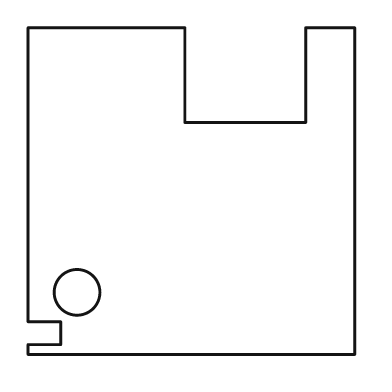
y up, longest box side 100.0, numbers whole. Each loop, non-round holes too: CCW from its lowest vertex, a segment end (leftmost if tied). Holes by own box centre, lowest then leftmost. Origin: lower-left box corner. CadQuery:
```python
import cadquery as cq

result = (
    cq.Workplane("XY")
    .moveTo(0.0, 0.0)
    .lineTo(100.0, 0.0)
    .lineTo(100.0, 100.0)
    .lineTo(85.0, 100.0)
    .lineTo(85.0, 71.0)
    .lineTo(48.0, 71.0)
    .lineTo(48.0, 100.0)
    .lineTo(0.0, 100.0)
    .lineTo(0.0, 10.0)
    .lineTo(10.0, 10.0)
    .lineTo(10.0, 3.0)
    .lineTo(0.0, 3.0)
    .close()
    .moveTo(15.0, 19.0)
    .circle(7.0)
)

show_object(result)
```